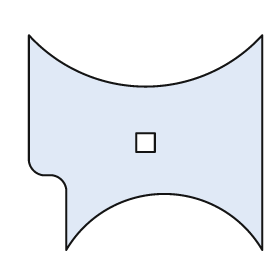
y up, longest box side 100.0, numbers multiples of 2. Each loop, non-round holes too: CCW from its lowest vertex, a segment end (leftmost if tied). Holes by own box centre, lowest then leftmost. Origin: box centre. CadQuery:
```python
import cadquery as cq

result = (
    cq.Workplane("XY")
    .moveTo(-34.0, -46.0)
    .threePointArc((8.0, -22.0), (50.0, -46.0))
    .lineTo(50.0, 46.0)
    .threePointArc((0.0, 24.0), (-50.0, 46.0))
    .lineTo(-50.0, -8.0)
    .threePointArc((-48.0, -12.0), (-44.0, -14.0))
    .lineTo(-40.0, -14.0)
    .threePointArc((-36.0, -16.0), (-34.0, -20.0))
    .close()
    .moveTo(-4.0, -4.0)
    .lineTo(4.0, -4.0)
    .lineTo(4.0, 4.0)
    .lineTo(-4.0, 4.0)
    .close()
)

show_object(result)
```